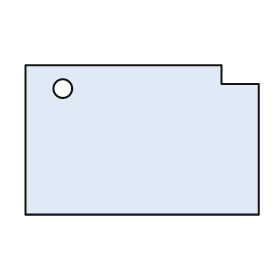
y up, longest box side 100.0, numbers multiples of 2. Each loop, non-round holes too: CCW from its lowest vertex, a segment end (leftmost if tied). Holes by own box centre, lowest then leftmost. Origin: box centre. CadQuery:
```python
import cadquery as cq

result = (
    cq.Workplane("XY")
    .moveTo(-50.0, -32.0)
    .lineTo(50.0, -32.0)
    .lineTo(50.0, 24.0)
    .lineTo(34.0, 24.0)
    .lineTo(34.0, 32.0)
    .lineTo(-50.0, 32.0)
    .close()
    .moveTo(-34.0, 22.0)
    .circle(4.0)
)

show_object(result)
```